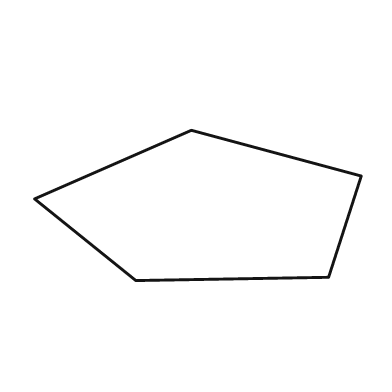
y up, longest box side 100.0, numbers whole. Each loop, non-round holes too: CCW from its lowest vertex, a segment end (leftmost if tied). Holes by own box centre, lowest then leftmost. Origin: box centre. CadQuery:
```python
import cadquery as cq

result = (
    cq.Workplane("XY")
    .moveTo(-19.0, -23.0)
    .lineTo(40.0, -22.0)
    .lineTo(50.0, 9.0)
    .lineTo(-2.0, 23.0)
    .lineTo(-50.0, 2.0)
    .close()
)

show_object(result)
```